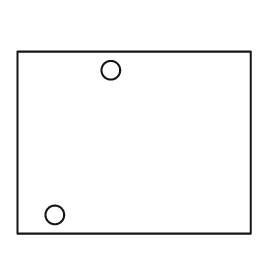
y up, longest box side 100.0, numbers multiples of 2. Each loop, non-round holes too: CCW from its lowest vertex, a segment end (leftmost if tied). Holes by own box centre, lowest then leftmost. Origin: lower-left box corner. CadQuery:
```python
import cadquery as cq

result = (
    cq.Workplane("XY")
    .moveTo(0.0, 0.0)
    .lineTo(100.0, 0.0)
    .lineTo(100.0, 78.0)
    .lineTo(0.0, 78.0)
    .close()
    .moveTo(16.0, 8.0)
    .circle(4.0)
    .moveTo(40.0, 70.0)
    .circle(4.0)
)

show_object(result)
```